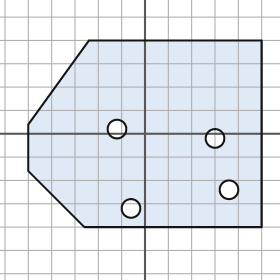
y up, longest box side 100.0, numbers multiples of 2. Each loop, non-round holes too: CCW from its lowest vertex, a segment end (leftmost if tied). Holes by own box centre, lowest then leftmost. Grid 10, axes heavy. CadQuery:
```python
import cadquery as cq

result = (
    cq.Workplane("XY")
    .moveTo(-26.0, -40.0)
    .lineTo(50.0, -40.0)
    .lineTo(50.0, 40.0)
    .lineTo(-24.0, 40.0)
    .lineTo(-50.0, 4.0)
    .lineTo(-50.0, -16.0)
    .close()
    .moveTo(-6.0, -32.0)
    .circle(4.0)
    .moveTo(36.0, -24.0)
    .circle(4.0)
    .moveTo(30.0, -2.0)
    .circle(4.0)
    .moveTo(-12.0, 2.0)
    .circle(4.0)
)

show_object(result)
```